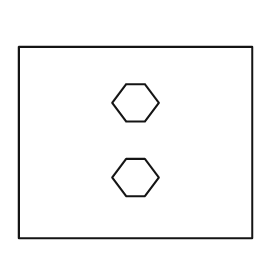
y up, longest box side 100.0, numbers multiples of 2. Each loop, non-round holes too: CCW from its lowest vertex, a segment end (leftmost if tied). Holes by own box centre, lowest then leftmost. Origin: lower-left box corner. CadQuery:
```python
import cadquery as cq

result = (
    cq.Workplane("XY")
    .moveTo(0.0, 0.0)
    .lineTo(100.0, 0.0)
    .lineTo(100.0, 82.0)
    .lineTo(0.0, 82.0)
    .close()
    .moveTo(46.0, 18.0)
    .lineTo(54.0, 18.0)
    .lineTo(60.0, 26.0)
    .lineTo(54.0, 34.0)
    .lineTo(46.0, 34.0)
    .lineTo(40.0, 26.0)
    .close()
    .moveTo(46.0, 50.0)
    .lineTo(54.0, 50.0)
    .lineTo(60.0, 58.0)
    .lineTo(54.0, 66.0)
    .lineTo(46.0, 66.0)
    .lineTo(40.0, 58.0)
    .close()
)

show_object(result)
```